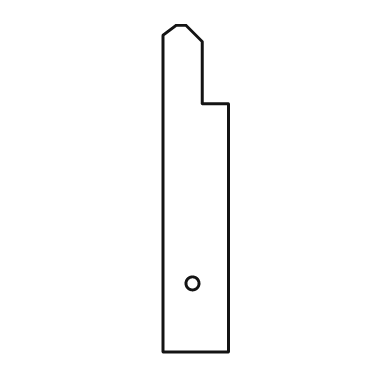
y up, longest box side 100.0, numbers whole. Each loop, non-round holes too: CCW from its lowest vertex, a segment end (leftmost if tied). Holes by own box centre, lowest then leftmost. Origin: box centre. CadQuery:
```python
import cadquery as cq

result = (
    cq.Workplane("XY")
    .moveTo(-10.0, -50.0)
    .lineTo(10.0, -50.0)
    .lineTo(10.0, 26.0)
    .lineTo(2.0, 26.0)
    .lineTo(2.0, 45.0)
    .lineTo(-3.0, 50.0)
    .lineTo(-6.0, 50.0)
    .lineTo(-10.0, 47.0)
    .close()
    .moveTo(-1.0, -29.0)
    .circle(2.0)
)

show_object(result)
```